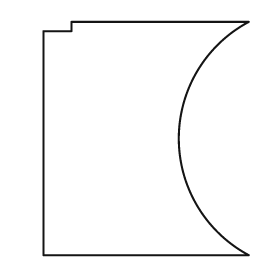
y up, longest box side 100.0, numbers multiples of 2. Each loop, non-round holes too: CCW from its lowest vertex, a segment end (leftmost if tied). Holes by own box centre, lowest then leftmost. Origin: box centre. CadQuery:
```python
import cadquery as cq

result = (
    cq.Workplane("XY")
    .moveTo(-44.0, -50.0)
    .lineTo(44.0, -50.0)
    .threePointArc((14.0, 0.0), (44.0, 50.0))
    .lineTo(-32.0, 50.0)
    .lineTo(-32.0, 46.0)
    .lineTo(-44.0, 46.0)
    .close()
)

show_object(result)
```